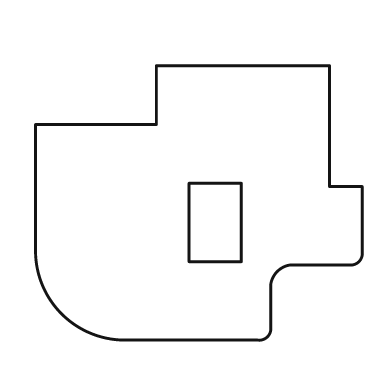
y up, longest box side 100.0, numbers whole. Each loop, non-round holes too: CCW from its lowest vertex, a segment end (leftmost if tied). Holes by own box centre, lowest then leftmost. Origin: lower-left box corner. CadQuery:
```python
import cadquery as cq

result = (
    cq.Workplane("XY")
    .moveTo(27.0, 0.0)
    .lineTo(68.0, 0.0)
    .threePointArc((71.0, 1.0), (72.0, 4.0))
    .lineTo(72.0, 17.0)
    .threePointArc((74.0, 21.0), (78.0, 23.0))
    .lineTo(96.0, 23.0)
    .threePointArc((99.0, 24.0), (100.0, 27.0))
    .lineTo(100.0, 47.0)
    .lineTo(90.0, 47.0)
    .lineTo(90.0, 84.0)
    .lineTo(37.0, 84.0)
    .lineTo(37.0, 66.0)
    .lineTo(0.0, 66.0)
    .lineTo(0.0, 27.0)
    .threePointArc((8.0, 8.0), (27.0, 0.0))
    .close()
    .moveTo(47.0, 24.0)
    .lineTo(63.0, 24.0)
    .lineTo(63.0, 48.0)
    .lineTo(47.0, 48.0)
    .close()
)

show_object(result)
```